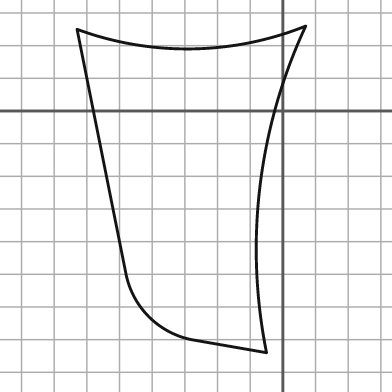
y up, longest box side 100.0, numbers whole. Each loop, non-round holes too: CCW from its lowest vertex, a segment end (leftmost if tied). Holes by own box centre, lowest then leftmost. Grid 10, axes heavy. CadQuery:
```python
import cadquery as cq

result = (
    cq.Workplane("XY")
    .moveTo(-5.0, -74.0)
    .threePointArc((-7.0, -23.0), (7.0, 26.0))
    .threePointArc((-28.0, 19.0), (-63.0, 25.0))
    .lineTo(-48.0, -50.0)
    .threePointArc((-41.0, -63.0), (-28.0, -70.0))
    .close()
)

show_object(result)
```